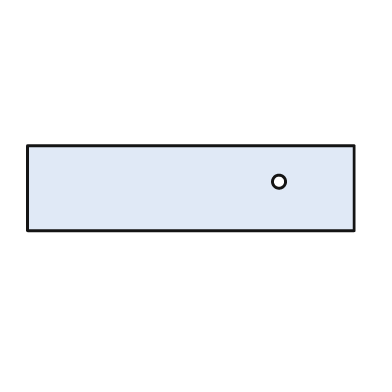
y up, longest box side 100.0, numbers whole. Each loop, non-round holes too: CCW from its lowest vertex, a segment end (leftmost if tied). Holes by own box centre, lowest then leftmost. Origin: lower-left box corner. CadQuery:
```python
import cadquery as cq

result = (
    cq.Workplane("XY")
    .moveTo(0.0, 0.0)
    .lineTo(100.0, 0.0)
    .lineTo(100.0, 26.0)
    .lineTo(0.0, 26.0)
    .close()
    .moveTo(77.0, 15.0)
    .circle(2.0)
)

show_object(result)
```